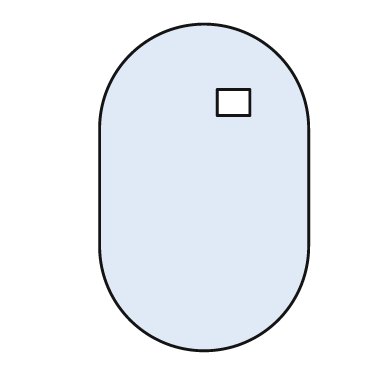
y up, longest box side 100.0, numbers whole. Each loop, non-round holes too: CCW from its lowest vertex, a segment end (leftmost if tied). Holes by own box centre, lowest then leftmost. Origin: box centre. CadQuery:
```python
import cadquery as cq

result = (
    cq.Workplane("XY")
    .moveTo(-32.0, -18.0)
    .threePointArc((0.0, -50.0), (32.0, -18.0))
    .lineTo(32.0, 18.0)
    .threePointArc((0.0, 50.0), (-32.0, 18.0))
    .close()
    .moveTo(4.0, 22.0)
    .lineTo(14.0, 22.0)
    .lineTo(14.0, 30.0)
    .lineTo(4.0, 30.0)
    .close()
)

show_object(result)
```